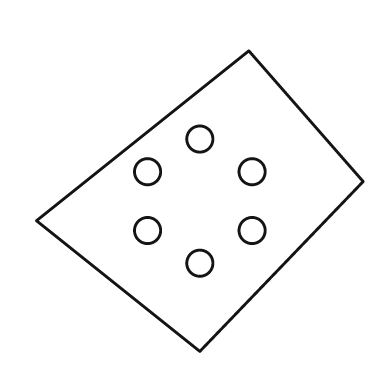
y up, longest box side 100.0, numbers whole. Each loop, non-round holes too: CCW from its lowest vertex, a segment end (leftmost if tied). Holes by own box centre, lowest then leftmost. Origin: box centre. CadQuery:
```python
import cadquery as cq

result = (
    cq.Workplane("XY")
    .moveTo(0.0, -46.0)
    .lineTo(50.0, 6.0)
    .lineTo(15.0, 46.0)
    .lineTo(-50.0, -6.0)
    .close()
    .moveTo(0.0, -19.0)
    .circle(4.0)
    .moveTo(-16.0, -9.0)
    .circle(4.0)
    .moveTo(16.0, -9.0)
    .circle(4.0)
    .moveTo(-16.0, 9.0)
    .circle(4.0)
    .moveTo(16.0, 9.0)
    .circle(4.0)
    .moveTo(0.0, 19.0)
    .circle(4.0)
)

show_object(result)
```